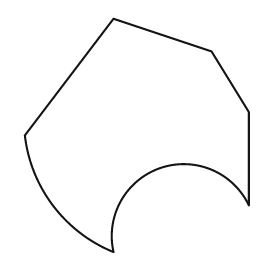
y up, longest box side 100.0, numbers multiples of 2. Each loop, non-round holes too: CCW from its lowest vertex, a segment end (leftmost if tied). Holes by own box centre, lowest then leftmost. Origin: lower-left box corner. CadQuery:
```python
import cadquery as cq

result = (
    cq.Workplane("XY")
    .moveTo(38.0, 0.0)
    .threePointArc((58.0, 36.0), (96.0, 20.0))
    .lineTo(96.0, 60.0)
    .lineTo(80.0, 86.0)
    .lineTo(38.0, 100.0)
    .lineTo(0.0, 50.0)
    .threePointArc((12.0, 20.0), (38.0, 0.0))
    .close()
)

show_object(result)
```